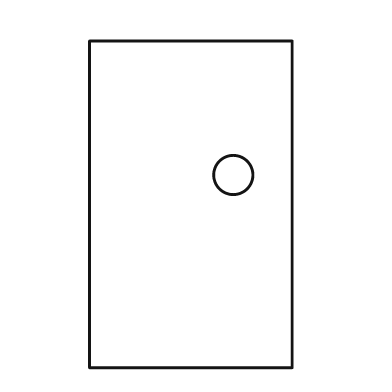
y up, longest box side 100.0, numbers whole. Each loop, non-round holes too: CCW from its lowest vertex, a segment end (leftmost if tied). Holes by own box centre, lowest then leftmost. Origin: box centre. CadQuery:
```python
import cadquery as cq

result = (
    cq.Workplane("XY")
    .moveTo(-31.0, -50.0)
    .lineTo(31.0, -50.0)
    .lineTo(31.0, 50.0)
    .lineTo(-31.0, 50.0)
    .close()
    .moveTo(13.0, 9.0)
    .circle(6.0)
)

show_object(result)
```